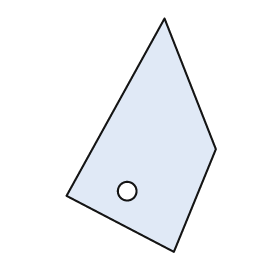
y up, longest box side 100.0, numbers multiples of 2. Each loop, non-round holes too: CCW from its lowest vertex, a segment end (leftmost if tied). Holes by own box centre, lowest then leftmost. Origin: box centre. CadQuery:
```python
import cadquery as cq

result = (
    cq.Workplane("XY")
    .moveTo(14.0, -50.0)
    .lineTo(32.0, -6.0)
    .lineTo(10.0, 50.0)
    .lineTo(-32.0, -26.0)
    .close()
    .moveTo(-6.0, -24.0)
    .circle(4.0)
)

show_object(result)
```